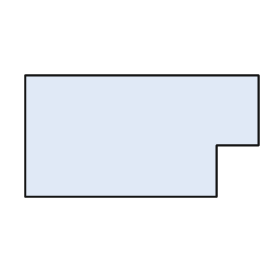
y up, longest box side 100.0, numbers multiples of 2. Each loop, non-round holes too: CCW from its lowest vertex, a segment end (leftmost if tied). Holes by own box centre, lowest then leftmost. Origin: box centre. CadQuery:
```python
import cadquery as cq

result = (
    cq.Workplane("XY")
    .moveTo(-50.0, -26.0)
    .lineTo(32.0, -26.0)
    .lineTo(32.0, -4.0)
    .lineTo(50.0, -4.0)
    .lineTo(50.0, 26.0)
    .lineTo(-50.0, 26.0)
    .close()
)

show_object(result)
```